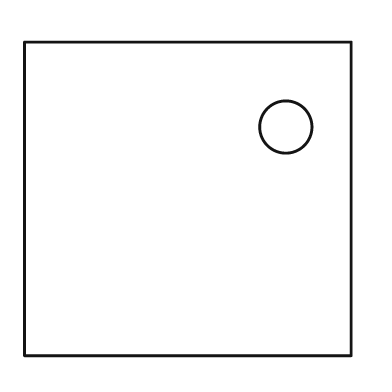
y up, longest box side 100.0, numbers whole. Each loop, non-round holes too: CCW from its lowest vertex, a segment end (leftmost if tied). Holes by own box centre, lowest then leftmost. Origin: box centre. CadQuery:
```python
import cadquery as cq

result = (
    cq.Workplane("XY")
    .moveTo(-50.0, -48.0)
    .lineTo(50.0, -48.0)
    .lineTo(50.0, 48.0)
    .lineTo(-50.0, 48.0)
    .close()
    .moveTo(30.0, 22.0)
    .circle(8.0)
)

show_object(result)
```